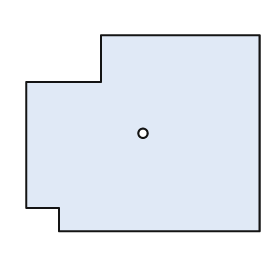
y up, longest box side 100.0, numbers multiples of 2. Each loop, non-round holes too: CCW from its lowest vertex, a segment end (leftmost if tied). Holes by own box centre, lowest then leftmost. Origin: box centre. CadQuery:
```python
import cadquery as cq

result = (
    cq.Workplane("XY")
    .moveTo(-36.0, -42.0)
    .lineTo(50.0, -42.0)
    .lineTo(50.0, 42.0)
    .lineTo(-18.0, 42.0)
    .lineTo(-18.0, 22.0)
    .lineTo(-50.0, 22.0)
    .lineTo(-50.0, -32.0)
    .lineTo(-36.0, -32.0)
    .close()
    .moveTo(0.0, 0.0)
    .circle(2.0)
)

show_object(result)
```